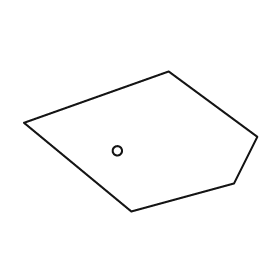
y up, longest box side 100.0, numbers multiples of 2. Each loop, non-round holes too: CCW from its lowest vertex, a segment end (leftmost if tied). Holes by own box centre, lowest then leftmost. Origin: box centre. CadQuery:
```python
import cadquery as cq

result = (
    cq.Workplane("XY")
    .moveTo(-4.0, -30.0)
    .lineTo(40.0, -18.0)
    .lineTo(50.0, 2.0)
    .lineTo(12.0, 30.0)
    .lineTo(-50.0, 8.0)
    .close()
    .moveTo(-10.0, -4.0)
    .circle(2.0)
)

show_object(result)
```